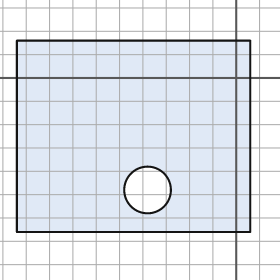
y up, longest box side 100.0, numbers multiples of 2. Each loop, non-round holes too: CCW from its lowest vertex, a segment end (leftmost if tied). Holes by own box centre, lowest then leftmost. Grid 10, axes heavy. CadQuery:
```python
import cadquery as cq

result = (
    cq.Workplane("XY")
    .moveTo(-94.0, -66.0)
    .lineTo(6.0, -66.0)
    .lineTo(6.0, 16.0)
    .lineTo(-94.0, 16.0)
    .close()
    .moveTo(-38.0, -48.0)
    .circle(10.0)
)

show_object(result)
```